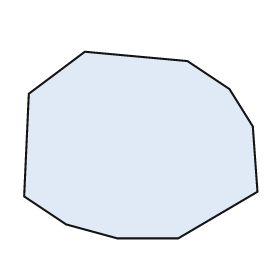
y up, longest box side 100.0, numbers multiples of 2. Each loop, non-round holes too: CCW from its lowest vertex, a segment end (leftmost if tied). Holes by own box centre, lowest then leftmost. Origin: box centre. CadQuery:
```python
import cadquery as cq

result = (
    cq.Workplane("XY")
    .moveTo(-10.0, -40.0)
    .lineTo(16.0, -40.0)
    .lineTo(50.0, -20.0)
    .lineTo(48.0, 8.0)
    .lineTo(38.0, 24.0)
    .lineTo(20.0, 36.0)
    .lineTo(-24.0, 40.0)
    .lineTo(-48.0, 22.0)
    .lineTo(-50.0, -22.0)
    .lineTo(-32.0, -34.0)
    .close()
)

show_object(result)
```